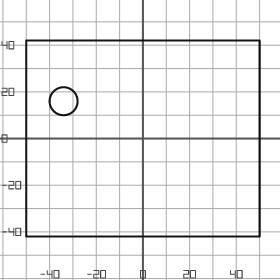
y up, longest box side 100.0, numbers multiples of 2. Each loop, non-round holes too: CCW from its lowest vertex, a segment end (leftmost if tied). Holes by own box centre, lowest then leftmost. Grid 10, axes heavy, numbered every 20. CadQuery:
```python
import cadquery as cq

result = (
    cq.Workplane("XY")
    .moveTo(-50.0, -42.0)
    .lineTo(50.0, -42.0)
    .lineTo(50.0, 42.0)
    .lineTo(-50.0, 42.0)
    .close()
    .moveTo(-34.0, 16.0)
    .circle(6.0)
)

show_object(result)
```